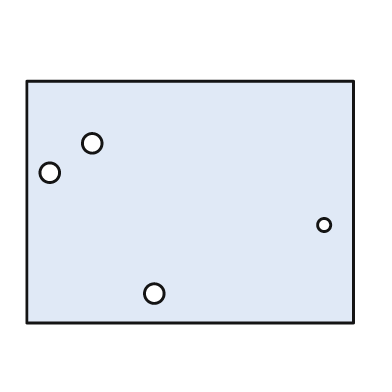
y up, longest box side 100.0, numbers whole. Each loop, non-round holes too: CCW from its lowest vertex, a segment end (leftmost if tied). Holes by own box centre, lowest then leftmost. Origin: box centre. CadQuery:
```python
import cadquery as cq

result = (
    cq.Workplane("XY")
    .moveTo(-50.0, -37.0)
    .lineTo(50.0, -37.0)
    .lineTo(50.0, 37.0)
    .lineTo(-50.0, 37.0)
    .close()
    .moveTo(-11.0, -28.0)
    .circle(3.0)
    .moveTo(41.0, -7.0)
    .circle(2.0)
    .moveTo(-43.0, 9.0)
    .circle(3.0)
    .moveTo(-30.0, 18.0)
    .circle(3.0)
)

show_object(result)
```